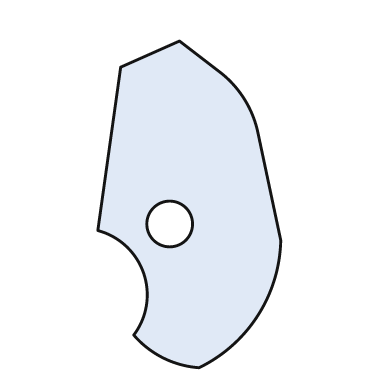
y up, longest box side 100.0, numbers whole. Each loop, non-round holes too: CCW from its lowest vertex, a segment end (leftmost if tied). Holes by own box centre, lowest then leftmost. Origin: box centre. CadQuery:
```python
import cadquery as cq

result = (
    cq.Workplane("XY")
    .moveTo(3.0, -50.0)
    .threePointArc((21.0, -34.0), (28.0, -11.0))
    .lineTo(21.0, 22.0)
    .threePointArc((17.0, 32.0), (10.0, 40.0))
    .lineTo(-3.0, 50.0)
    .lineTo(-21.0, 42.0)
    .lineTo(-28.0, -8.0)
    .threePointArc((-14.0, -21.0), (-17.0, -40.0))
    .threePointArc((-8.0, -47.0), (3.0, -50.0))
    .close()
    .moveTo(-6.0, -6.0)
    .circle(7.0)
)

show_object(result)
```